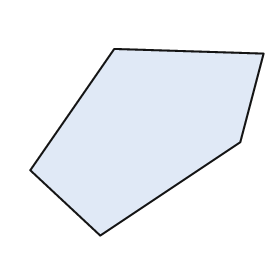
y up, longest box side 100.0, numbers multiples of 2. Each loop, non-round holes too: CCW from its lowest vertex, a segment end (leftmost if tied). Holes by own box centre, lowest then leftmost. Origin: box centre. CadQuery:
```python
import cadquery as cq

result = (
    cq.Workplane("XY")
    .moveTo(-20.0, -40.0)
    .lineTo(40.0, 0.0)
    .lineTo(50.0, 38.0)
    .lineTo(-14.0, 40.0)
    .lineTo(-50.0, -12.0)
    .close()
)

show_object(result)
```